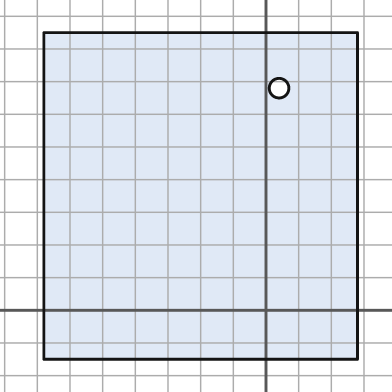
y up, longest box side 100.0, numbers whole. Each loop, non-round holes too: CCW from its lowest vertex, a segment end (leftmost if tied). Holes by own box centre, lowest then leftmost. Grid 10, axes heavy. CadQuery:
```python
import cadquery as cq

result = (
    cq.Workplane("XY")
    .moveTo(-68.0, -15.0)
    .lineTo(28.0, -15.0)
    .lineTo(28.0, 85.0)
    .lineTo(-68.0, 85.0)
    .close()
    .moveTo(4.0, 68.0)
    .circle(3.0)
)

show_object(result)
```